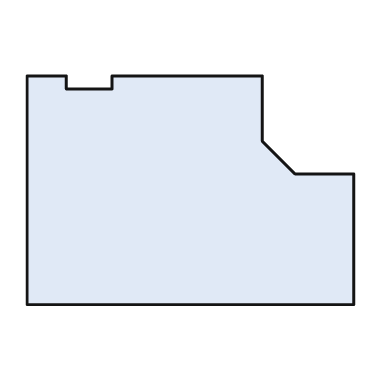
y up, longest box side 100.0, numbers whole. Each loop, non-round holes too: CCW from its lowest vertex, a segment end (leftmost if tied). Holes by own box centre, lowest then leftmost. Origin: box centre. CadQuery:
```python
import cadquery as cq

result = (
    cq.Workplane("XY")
    .moveTo(-50.0, -35.0)
    .lineTo(50.0, -35.0)
    .lineTo(50.0, 5.0)
    .lineTo(32.0, 5.0)
    .lineTo(22.0, 15.0)
    .lineTo(22.0, 35.0)
    .lineTo(-24.0, 35.0)
    .lineTo(-24.0, 31.0)
    .lineTo(-38.0, 31.0)
    .lineTo(-38.0, 35.0)
    .lineTo(-50.0, 35.0)
    .close()
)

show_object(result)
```